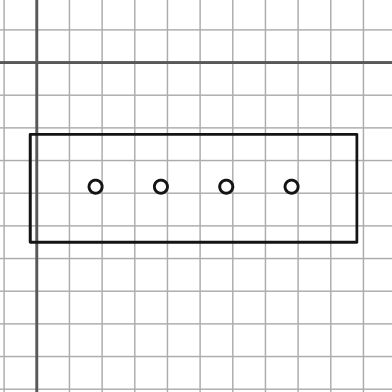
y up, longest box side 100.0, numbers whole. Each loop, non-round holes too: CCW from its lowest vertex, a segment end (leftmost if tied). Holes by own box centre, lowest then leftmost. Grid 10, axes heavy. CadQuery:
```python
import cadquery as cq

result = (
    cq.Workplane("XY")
    .moveTo(-2.0, -55.0)
    .lineTo(98.0, -55.0)
    .lineTo(98.0, -22.0)
    .lineTo(-2.0, -22.0)
    .close()
    .moveTo(18.0, -38.0)
    .circle(2.0)
    .moveTo(38.0, -38.0)
    .circle(2.0)
    .moveTo(58.0, -38.0)
    .circle(2.0)
    .moveTo(78.0, -38.0)
    .circle(2.0)
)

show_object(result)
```